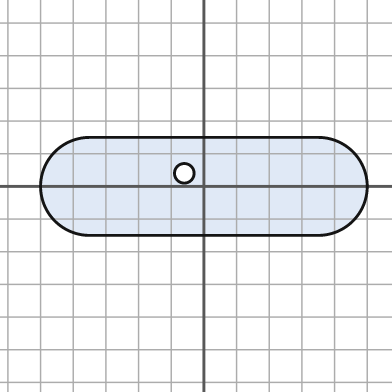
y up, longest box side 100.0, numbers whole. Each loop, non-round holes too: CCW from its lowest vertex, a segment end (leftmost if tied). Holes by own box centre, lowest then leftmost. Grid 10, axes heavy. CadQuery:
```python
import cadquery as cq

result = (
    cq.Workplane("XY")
    .moveTo(-35.0, -15.0)
    .lineTo(35.0, -15.0)
    .threePointArc((50.0, 0.0), (35.0, 15.0))
    .lineTo(-35.0, 15.0)
    .threePointArc((-50.0, 0.0), (-35.0, -15.0))
    .close()
    .moveTo(-6.0, 4.0)
    .circle(3.0)
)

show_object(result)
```